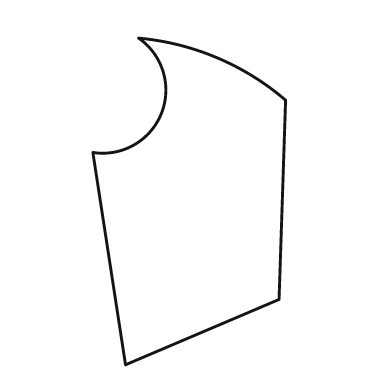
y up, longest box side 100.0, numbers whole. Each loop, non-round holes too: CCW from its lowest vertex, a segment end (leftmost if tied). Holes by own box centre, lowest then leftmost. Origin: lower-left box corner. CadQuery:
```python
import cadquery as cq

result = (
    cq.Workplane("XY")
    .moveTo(10.0, 0.0)
    .lineTo(57.0, 20.0)
    .lineTo(59.0, 81.0)
    .threePointArc((38.0, 94.0), (14.0, 100.0))
    .threePointArc((21.0, 77.0), (0.0, 65.0))
    .close()
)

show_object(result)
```